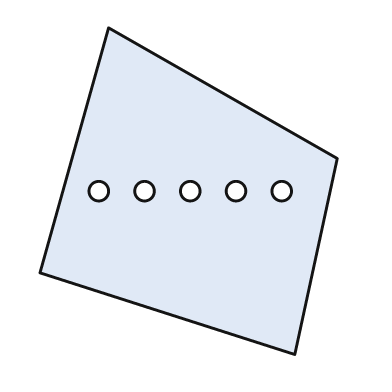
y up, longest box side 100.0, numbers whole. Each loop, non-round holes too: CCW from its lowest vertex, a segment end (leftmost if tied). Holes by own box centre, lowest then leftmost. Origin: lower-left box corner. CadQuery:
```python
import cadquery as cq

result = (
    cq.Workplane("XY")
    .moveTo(78.0, 0.0)
    .lineTo(91.0, 60.0)
    .lineTo(21.0, 100.0)
    .lineTo(0.0, 25.0)
    .close()
    .moveTo(18.0, 50.0)
    .circle(3.0)
    .moveTo(32.0, 50.0)
    .circle(3.0)
    .moveTo(46.0, 50.0)
    .circle(3.0)
    .moveTo(60.0, 50.0)
    .circle(3.0)
    .moveTo(74.0, 50.0)
    .circle(3.0)
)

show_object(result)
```